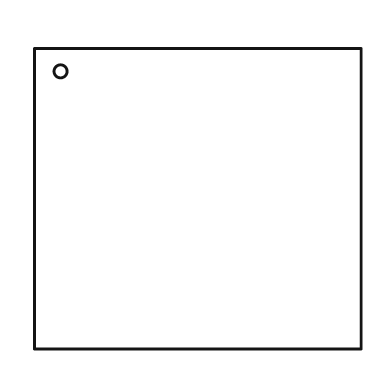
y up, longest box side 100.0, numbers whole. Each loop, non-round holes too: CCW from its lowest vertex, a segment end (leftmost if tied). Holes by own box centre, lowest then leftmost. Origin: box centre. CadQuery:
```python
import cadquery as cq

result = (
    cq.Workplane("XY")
    .moveTo(-50.0, -46.0)
    .lineTo(50.0, -46.0)
    .lineTo(50.0, 46.0)
    .lineTo(-50.0, 46.0)
    .close()
    .moveTo(-42.0, 39.0)
    .circle(2.0)
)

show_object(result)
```